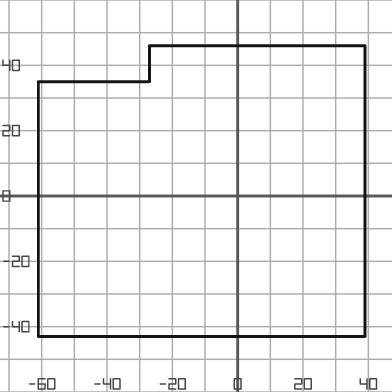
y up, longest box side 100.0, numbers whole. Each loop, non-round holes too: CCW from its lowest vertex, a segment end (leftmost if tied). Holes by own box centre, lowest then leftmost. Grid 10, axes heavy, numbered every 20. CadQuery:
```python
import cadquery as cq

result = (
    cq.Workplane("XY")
    .moveTo(-61.0, -43.0)
    .lineTo(39.0, -43.0)
    .lineTo(39.0, 46.0)
    .lineTo(-27.0, 46.0)
    .lineTo(-27.0, 35.0)
    .lineTo(-61.0, 35.0)
    .close()
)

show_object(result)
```